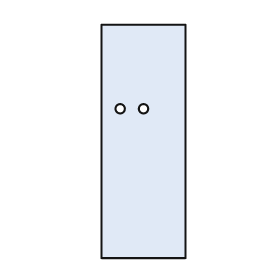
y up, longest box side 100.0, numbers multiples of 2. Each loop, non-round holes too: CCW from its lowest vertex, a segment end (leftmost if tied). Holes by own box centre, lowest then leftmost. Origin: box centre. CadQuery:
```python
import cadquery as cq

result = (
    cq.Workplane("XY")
    .moveTo(-18.0, -50.0)
    .lineTo(18.0, -50.0)
    .lineTo(18.0, 50.0)
    .lineTo(-18.0, 50.0)
    .close()
    .moveTo(-10.0, 14.0)
    .circle(2.0)
    .moveTo(0.0, 14.0)
    .circle(2.0)
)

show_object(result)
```